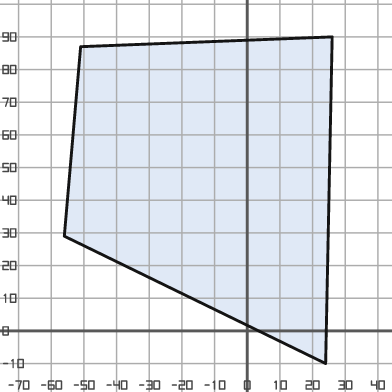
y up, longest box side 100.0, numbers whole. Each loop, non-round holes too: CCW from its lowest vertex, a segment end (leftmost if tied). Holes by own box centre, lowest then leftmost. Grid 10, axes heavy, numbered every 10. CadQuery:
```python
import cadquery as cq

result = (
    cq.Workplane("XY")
    .moveTo(24.0, -10.0)
    .lineTo(26.0, 90.0)
    .lineTo(-51.0, 87.0)
    .lineTo(-56.0, 29.0)
    .close()
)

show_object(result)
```